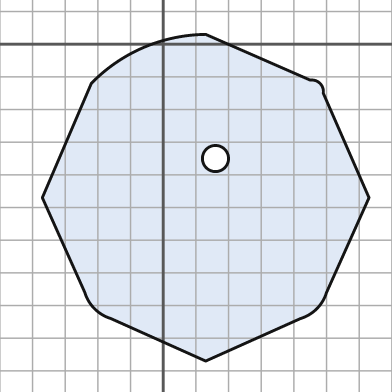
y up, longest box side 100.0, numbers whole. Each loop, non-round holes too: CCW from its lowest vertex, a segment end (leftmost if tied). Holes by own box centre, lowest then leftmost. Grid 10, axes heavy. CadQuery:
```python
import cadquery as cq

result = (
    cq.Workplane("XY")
    .moveTo(13.0, -97.0)
    .lineTo(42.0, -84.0)
    .threePointArc((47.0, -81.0), (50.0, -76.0))
    .lineTo(63.0, -47.0)
    .lineTo(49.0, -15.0)
    .threePointArc((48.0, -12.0), (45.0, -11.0))
    .lineTo(13.0, 3.0)
    .threePointArc((-6.0, -1.0), (-22.0, -12.0))
    .lineTo(-37.0, -47.0)
    .lineTo(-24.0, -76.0)
    .threePointArc((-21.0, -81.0), (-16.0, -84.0))
    .close()
    .moveTo(16.0, -35.0)
    .circle(4.0)
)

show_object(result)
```